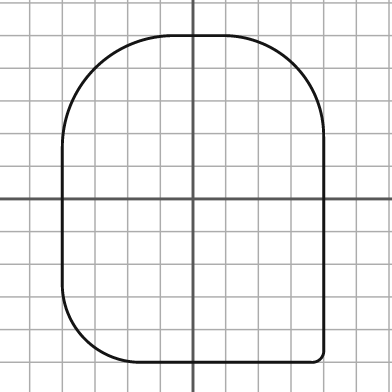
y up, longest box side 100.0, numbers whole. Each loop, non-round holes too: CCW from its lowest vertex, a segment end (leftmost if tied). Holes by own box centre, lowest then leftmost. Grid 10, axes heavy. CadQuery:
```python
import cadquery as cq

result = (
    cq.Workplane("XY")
    .moveTo(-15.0, -50.0)
    .lineTo(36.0, -50.0)
    .threePointArc((39.0, -49.0), (40.0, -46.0))
    .lineTo(40.0, 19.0)
    .threePointArc((31.0, 41.0), (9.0, 50.0))
    .lineTo(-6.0, 50.0)
    .threePointArc((-30.0, 40.0), (-40.0, 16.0))
    .lineTo(-40.0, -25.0)
    .threePointArc((-33.0, -43.0), (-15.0, -50.0))
    .close()
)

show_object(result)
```